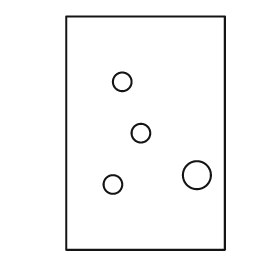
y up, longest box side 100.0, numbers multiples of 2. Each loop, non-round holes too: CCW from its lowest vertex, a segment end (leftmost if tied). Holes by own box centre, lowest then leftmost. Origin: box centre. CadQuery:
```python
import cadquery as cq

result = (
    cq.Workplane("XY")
    .moveTo(-34.0, -50.0)
    .lineTo(34.0, -50.0)
    .lineTo(34.0, 50.0)
    .lineTo(-34.0, 50.0)
    .close()
    .moveTo(-14.0, -22.0)
    .circle(4.0)
    .moveTo(22.0, -18.0)
    .circle(6.0)
    .moveTo(-2.0, 0.0)
    .circle(4.0)
    .moveTo(-10.0, 22.0)
    .circle(4.0)
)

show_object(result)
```